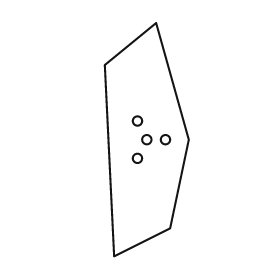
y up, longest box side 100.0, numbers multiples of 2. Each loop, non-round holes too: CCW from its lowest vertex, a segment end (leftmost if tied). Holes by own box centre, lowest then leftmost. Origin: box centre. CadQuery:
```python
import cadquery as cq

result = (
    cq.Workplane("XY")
    .moveTo(-14.0, -50.0)
    .lineTo(10.0, -38.0)
    .lineTo(18.0, 0.0)
    .lineTo(4.0, 50.0)
    .lineTo(-18.0, 32.0)
    .close()
    .moveTo(-4.0, -8.0)
    .circle(2.0)
    .moveTo(0.0, 0.0)
    .circle(2.0)
    .moveTo(8.0, 0.0)
    .circle(2.0)
    .moveTo(-4.0, 8.0)
    .circle(2.0)
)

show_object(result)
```